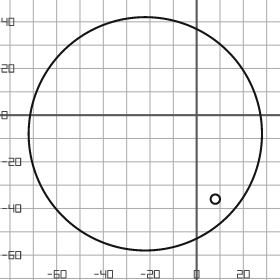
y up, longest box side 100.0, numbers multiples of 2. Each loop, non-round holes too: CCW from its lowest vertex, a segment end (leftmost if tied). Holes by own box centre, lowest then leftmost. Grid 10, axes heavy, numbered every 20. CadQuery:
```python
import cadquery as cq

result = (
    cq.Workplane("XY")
    .moveTo(-22.0, -8.0)
    .circle(50.0)
    .moveTo(8.0, -36.0)
    .circle(2.0)
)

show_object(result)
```